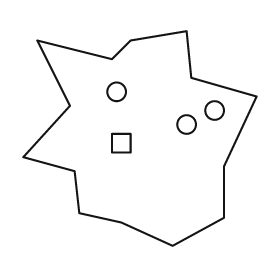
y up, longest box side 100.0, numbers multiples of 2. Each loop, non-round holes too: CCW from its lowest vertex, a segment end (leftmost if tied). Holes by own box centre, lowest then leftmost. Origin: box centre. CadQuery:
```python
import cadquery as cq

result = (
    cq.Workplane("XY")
    .moveTo(14.0, -46.0)
    .lineTo(36.0, -34.0)
    .lineTo(36.0, -12.0)
    .lineTo(50.0, 18.0)
    .lineTo(22.0, 26.0)
    .lineTo(20.0, 46.0)
    .lineTo(-4.0, 42.0)
    .lineTo(-12.0, 34.0)
    .lineTo(-44.0, 42.0)
    .lineTo(-30.0, 14.0)
    .lineTo(-50.0, -8.0)
    .lineTo(-28.0, -14.0)
    .lineTo(-26.0, -32.0)
    .lineTo(-8.0, -36.0)
    .close()
    .moveTo(-12.0, -6.0)
    .lineTo(-4.0, -6.0)
    .lineTo(-4.0, 2.0)
    .lineTo(-12.0, 2.0)
    .close()
    .moveTo(20.0, 6.0)
    .circle(4.0)
    .moveTo(32.0, 12.0)
    .circle(4.0)
    .moveTo(-10.0, 20.0)
    .circle(4.0)
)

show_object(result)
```